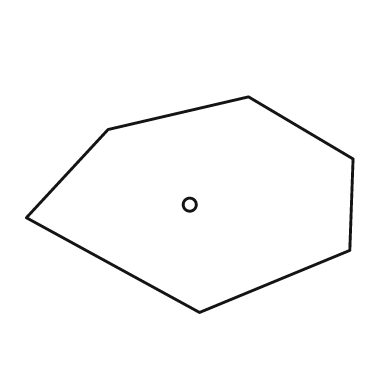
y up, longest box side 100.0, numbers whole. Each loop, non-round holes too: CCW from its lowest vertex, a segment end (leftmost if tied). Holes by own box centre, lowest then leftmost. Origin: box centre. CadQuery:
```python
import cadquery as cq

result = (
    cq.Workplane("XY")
    .moveTo(3.0, -33.0)
    .lineTo(49.0, -14.0)
    .lineTo(50.0, 14.0)
    .lineTo(18.0, 33.0)
    .lineTo(-25.0, 23.0)
    .lineTo(-50.0, -4.0)
    .close()
    .moveTo(0.0, 0.0)
    .circle(2.0)
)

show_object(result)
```